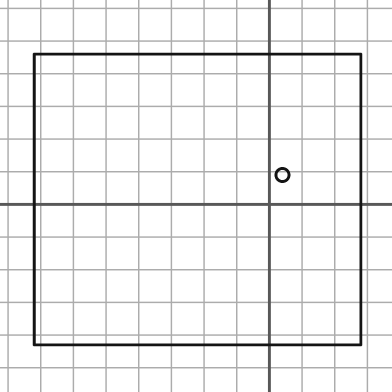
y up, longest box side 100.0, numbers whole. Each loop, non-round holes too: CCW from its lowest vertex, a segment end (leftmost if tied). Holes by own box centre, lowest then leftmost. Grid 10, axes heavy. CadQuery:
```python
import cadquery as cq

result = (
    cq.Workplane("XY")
    .moveTo(-72.0, -43.0)
    .lineTo(28.0, -43.0)
    .lineTo(28.0, 46.0)
    .lineTo(-72.0, 46.0)
    .close()
    .moveTo(4.0, 9.0)
    .circle(2.0)
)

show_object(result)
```